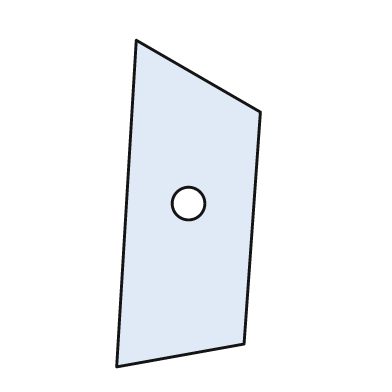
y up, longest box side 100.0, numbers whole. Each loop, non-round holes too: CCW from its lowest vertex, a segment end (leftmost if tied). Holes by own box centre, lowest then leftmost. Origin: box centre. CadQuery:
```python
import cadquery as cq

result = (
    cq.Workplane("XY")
    .moveTo(-22.0, -50.0)
    .lineTo(17.0, -43.0)
    .lineTo(22.0, 28.0)
    .lineTo(-16.0, 50.0)
    .close()
    .moveTo(0.0, 0.0)
    .circle(5.0)
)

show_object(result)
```